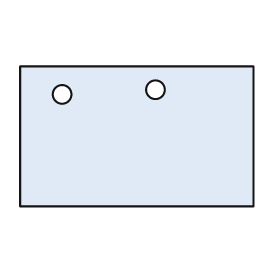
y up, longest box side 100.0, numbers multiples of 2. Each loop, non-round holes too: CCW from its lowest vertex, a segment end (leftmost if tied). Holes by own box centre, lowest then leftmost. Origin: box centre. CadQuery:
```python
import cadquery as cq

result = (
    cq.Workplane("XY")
    .moveTo(-50.0, -30.0)
    .lineTo(50.0, -30.0)
    .lineTo(50.0, 30.0)
    .lineTo(-50.0, 30.0)
    .close()
    .moveTo(-32.0, 18.0)
    .circle(4.0)
    .moveTo(8.0, 20.0)
    .circle(4.0)
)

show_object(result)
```